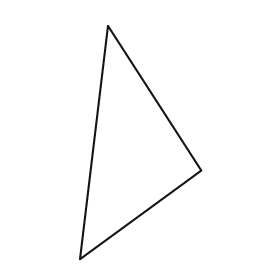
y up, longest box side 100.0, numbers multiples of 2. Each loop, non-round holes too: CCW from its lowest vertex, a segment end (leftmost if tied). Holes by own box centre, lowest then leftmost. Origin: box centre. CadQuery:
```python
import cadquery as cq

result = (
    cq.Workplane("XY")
    .moveTo(-26.0, -50.0)
    .lineTo(26.0, -12.0)
    .lineTo(-14.0, 50.0)
    .close()
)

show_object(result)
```